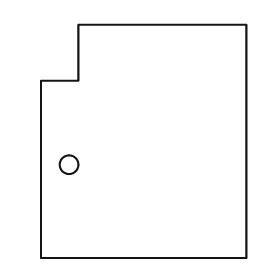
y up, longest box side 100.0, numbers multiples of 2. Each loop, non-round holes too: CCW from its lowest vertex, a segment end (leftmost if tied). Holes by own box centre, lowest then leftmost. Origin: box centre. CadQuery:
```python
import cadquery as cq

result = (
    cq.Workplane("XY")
    .moveTo(-44.0, -50.0)
    .lineTo(44.0, -50.0)
    .lineTo(44.0, 50.0)
    .lineTo(-28.0, 50.0)
    .lineTo(-28.0, 26.0)
    .lineTo(-44.0, 26.0)
    .close()
    .moveTo(-32.0, -10.0)
    .circle(4.0)
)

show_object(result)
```